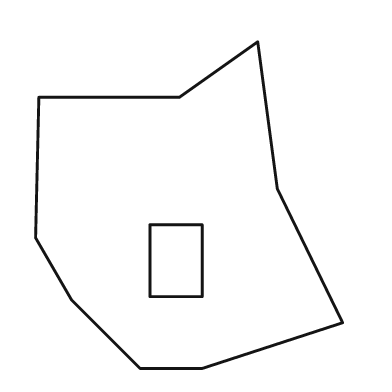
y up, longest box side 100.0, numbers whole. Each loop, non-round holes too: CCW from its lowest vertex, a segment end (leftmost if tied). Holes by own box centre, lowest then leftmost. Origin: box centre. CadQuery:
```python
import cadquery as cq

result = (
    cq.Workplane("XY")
    .moveTo(-15.0, -50.0)
    .lineTo(4.0, -50.0)
    .lineTo(47.0, -36.0)
    .lineTo(27.0, 5.0)
    .lineTo(21.0, 50.0)
    .lineTo(-3.0, 33.0)
    .lineTo(-46.0, 33.0)
    .lineTo(-47.0, -10.0)
    .lineTo(-36.0, -29.0)
    .close()
    .moveTo(-12.0, -28.0)
    .lineTo(4.0, -28.0)
    .lineTo(4.0, -6.0)
    .lineTo(-12.0, -6.0)
    .close()
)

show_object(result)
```